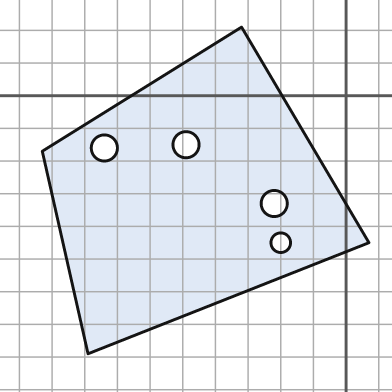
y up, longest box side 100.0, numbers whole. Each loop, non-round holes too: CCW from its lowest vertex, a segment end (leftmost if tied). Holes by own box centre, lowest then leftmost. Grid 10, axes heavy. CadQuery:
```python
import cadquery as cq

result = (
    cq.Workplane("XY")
    .moveTo(-79.0, -79.0)
    .lineTo(7.0, -45.0)
    .lineTo(-32.0, 21.0)
    .lineTo(-93.0, -17.0)
    .close()
    .moveTo(-20.0, -45.0)
    .circle(3.0)
    .moveTo(-22.0, -33.0)
    .circle(4.0)
    .moveTo(-74.0, -16.0)
    .circle(4.0)
    .moveTo(-49.0, -15.0)
    .circle(4.0)
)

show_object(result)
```